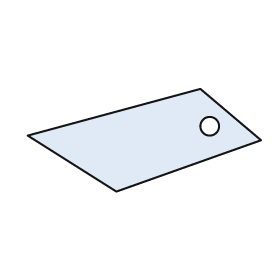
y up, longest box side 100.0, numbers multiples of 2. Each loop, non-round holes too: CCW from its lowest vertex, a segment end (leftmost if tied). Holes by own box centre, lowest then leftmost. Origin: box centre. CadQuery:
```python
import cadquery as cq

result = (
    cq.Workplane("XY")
    .moveTo(-12.0, -22.0)
    .lineTo(50.0, 0.0)
    .lineTo(24.0, 22.0)
    .lineTo(-50.0, 2.0)
    .close()
    .moveTo(28.0, 6.0)
    .circle(4.0)
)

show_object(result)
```